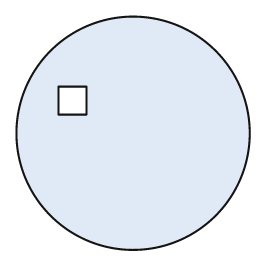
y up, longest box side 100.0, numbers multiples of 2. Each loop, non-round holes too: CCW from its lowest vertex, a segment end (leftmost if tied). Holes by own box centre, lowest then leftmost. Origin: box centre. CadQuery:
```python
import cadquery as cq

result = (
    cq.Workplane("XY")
    .moveTo(0.0, 0.0)
    .circle(50.0)
    .moveTo(-32.0, 8.0)
    .lineTo(-20.0, 8.0)
    .lineTo(-20.0, 20.0)
    .lineTo(-32.0, 20.0)
    .close()
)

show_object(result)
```